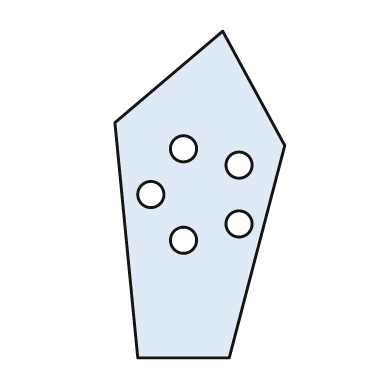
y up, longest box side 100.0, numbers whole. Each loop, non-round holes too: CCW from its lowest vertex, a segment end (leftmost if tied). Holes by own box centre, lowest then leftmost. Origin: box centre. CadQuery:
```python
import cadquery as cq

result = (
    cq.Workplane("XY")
    .moveTo(-19.0, -50.0)
    .lineTo(9.0, -50.0)
    .lineTo(26.0, 15.0)
    .lineTo(7.0, 50.0)
    .lineTo(-26.0, 22.0)
    .close()
    .moveTo(-5.0, -14.0)
    .circle(4.0)
    .moveTo(12.0, -9.0)
    .circle(4.0)
    .moveTo(-15.0, 0.0)
    .circle(4.0)
    .moveTo(12.0, 9.0)
    .circle(4.0)
    .moveTo(-5.0, 14.0)
    .circle(4.0)
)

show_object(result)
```